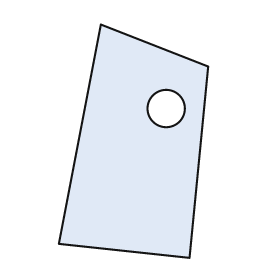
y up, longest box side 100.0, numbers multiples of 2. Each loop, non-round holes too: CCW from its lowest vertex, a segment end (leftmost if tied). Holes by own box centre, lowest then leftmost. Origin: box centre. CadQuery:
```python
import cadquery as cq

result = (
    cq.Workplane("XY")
    .moveTo(24.0, -50.0)
    .lineTo(32.0, 32.0)
    .lineTo(-14.0, 50.0)
    .lineTo(-32.0, -44.0)
    .close()
    .moveTo(14.0, 14.0)
    .circle(8.0)
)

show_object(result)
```